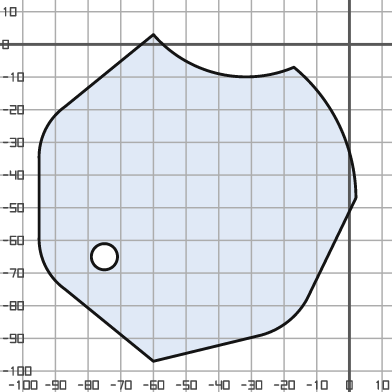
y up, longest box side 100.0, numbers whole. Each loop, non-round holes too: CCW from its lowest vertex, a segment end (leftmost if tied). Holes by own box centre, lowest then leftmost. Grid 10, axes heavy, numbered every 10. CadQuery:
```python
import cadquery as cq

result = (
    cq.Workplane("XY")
    .moveTo(-60.0, -97.0)
    .lineTo(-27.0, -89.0)
    .threePointArc((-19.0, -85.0), (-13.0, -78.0))
    .lineTo(2.0, -47.0)
    .threePointArc((-3.0, -25.0), (-17.0, -7.0))
    .threePointArc((-40.0, -9.0), (-60.0, 3.0))
    .lineTo(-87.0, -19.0)
    .threePointArc((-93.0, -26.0), (-95.0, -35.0))
    .lineTo(-95.0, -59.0)
    .threePointArc((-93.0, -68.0), (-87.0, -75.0))
    .close()
    .moveTo(-75.0, -65.0)
    .circle(4.0)
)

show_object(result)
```